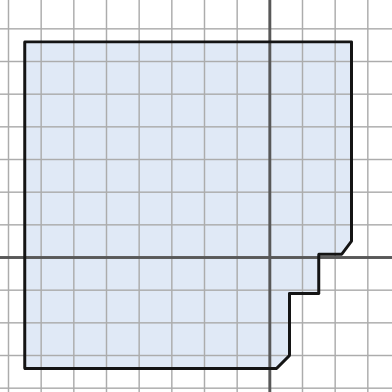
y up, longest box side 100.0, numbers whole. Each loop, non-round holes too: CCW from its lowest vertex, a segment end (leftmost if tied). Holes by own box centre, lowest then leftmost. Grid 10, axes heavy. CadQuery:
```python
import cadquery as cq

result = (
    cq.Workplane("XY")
    .moveTo(-75.0, -34.0)
    .lineTo(2.0, -34.0)
    .lineTo(6.0, -30.0)
    .lineTo(6.0, -11.0)
    .lineTo(15.0, -11.0)
    .lineTo(15.0, 1.0)
    .lineTo(22.0, 1.0)
    .lineTo(25.0, 5.0)
    .lineTo(25.0, 66.0)
    .lineTo(-75.0, 66.0)
    .close()
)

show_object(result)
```